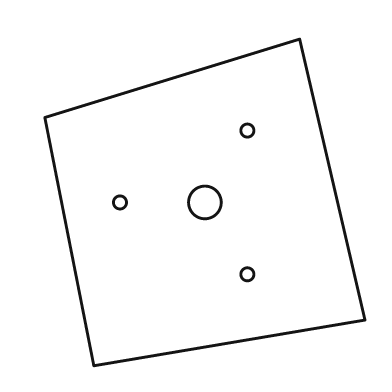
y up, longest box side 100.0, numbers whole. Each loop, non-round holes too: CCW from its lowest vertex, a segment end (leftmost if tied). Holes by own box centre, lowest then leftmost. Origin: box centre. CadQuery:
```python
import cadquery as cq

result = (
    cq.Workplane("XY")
    .moveTo(-34.0, -50.0)
    .lineTo(49.0, -36.0)
    .lineTo(29.0, 50.0)
    .lineTo(-49.0, 26.0)
    .close()
    .moveTo(13.0, -22.0)
    .circle(2.0)
    .moveTo(-26.0, 0.0)
    .circle(2.0)
    .moveTo(0.0, 0.0)
    .circle(5.0)
    .moveTo(13.0, 22.0)
    .circle(2.0)
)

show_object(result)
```